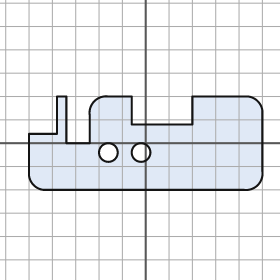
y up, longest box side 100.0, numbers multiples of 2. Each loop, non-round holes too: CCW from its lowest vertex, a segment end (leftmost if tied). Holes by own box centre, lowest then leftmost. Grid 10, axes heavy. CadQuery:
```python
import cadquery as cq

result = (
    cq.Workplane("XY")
    .moveTo(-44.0, -20.0)
    .lineTo(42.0, -20.0)
    .threePointArc((48.0, -18.0), (50.0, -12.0))
    .lineTo(50.0, 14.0)
    .threePointArc((48.0, 18.0), (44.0, 20.0))
    .lineTo(20.0, 20.0)
    .lineTo(20.0, 8.0)
    .lineTo(-6.0, 8.0)
    .lineTo(-6.0, 20.0)
    .lineTo(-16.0, 20.0)
    .threePointArc((-22.0, 18.0), (-24.0, 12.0))
    .lineTo(-24.0, 0.0)
    .lineTo(-34.0, 0.0)
    .lineTo(-34.0, 20.0)
    .lineTo(-38.0, 20.0)
    .lineTo(-38.0, 4.0)
    .lineTo(-50.0, 4.0)
    .lineTo(-50.0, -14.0)
    .threePointArc((-48.0, -18.0), (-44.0, -20.0))
    .close()
    .moveTo(-16.0, -4.0)
    .circle(4.0)
    .moveTo(-2.0, -4.0)
    .circle(4.0)
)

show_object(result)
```